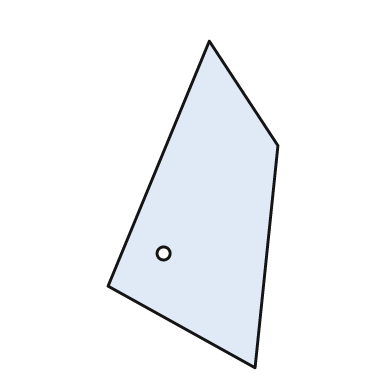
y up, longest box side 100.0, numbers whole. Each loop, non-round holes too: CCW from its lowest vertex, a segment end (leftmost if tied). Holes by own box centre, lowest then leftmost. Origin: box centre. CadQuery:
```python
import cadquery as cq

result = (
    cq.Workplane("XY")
    .moveTo(19.0, -50.0)
    .lineTo(26.0, 18.0)
    .lineTo(5.0, 50.0)
    .lineTo(-26.0, -25.0)
    .close()
    .moveTo(-9.0, -15.0)
    .circle(2.0)
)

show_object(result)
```